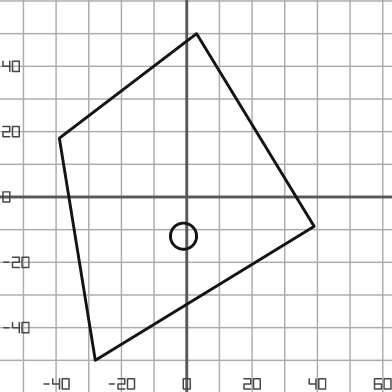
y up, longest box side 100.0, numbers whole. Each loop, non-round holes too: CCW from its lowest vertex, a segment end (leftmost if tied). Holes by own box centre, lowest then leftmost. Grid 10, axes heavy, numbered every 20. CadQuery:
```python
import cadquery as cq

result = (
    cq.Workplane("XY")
    .moveTo(-28.0, -50.0)
    .lineTo(39.0, -9.0)
    .lineTo(3.0, 50.0)
    .lineTo(-39.0, 18.0)
    .close()
    .moveTo(-1.0, -12.0)
    .circle(4.0)
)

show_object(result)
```